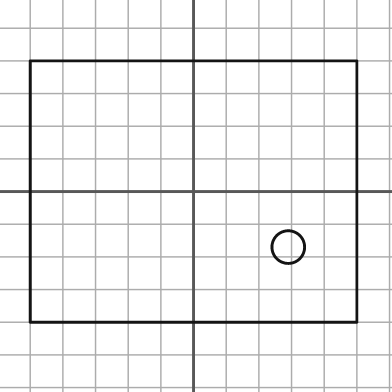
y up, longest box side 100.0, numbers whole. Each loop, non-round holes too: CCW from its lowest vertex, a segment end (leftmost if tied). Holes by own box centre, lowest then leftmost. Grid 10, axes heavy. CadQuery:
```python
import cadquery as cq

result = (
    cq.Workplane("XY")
    .moveTo(-50.0, -40.0)
    .lineTo(50.0, -40.0)
    .lineTo(50.0, 40.0)
    .lineTo(-50.0, 40.0)
    .close()
    .moveTo(29.0, -17.0)
    .circle(5.0)
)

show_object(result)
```